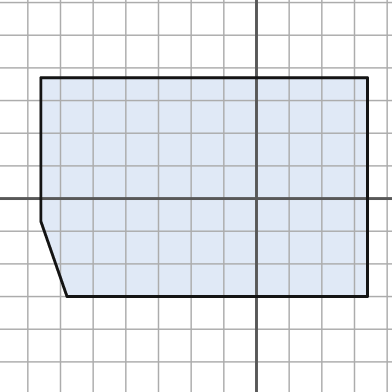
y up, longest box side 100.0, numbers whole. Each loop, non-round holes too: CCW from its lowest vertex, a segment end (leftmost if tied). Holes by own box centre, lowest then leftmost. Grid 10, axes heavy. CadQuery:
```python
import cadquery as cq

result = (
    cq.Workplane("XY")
    .moveTo(-58.0, -30.0)
    .lineTo(34.0, -30.0)
    .lineTo(34.0, 37.0)
    .lineTo(-66.0, 37.0)
    .lineTo(-66.0, -7.0)
    .close()
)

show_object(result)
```